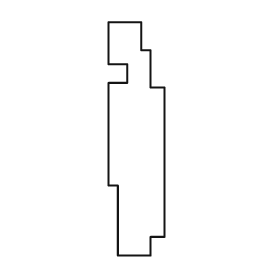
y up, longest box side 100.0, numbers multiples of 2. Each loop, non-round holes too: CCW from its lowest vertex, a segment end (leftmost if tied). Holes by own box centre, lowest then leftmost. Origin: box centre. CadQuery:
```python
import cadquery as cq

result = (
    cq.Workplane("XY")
    .moveTo(-8.0, -50.0)
    .lineTo(6.0, -50.0)
    .lineTo(6.0, -42.0)
    .lineTo(12.0, -42.0)
    .lineTo(12.0, 22.0)
    .lineTo(6.0, 22.0)
    .lineTo(6.0, 38.0)
    .lineTo(2.0, 38.0)
    .lineTo(2.0, 50.0)
    .lineTo(-12.0, 50.0)
    .lineTo(-12.0, 32.0)
    .lineTo(-4.0, 32.0)
    .lineTo(-4.0, 24.0)
    .lineTo(-12.0, 24.0)
    .lineTo(-12.0, -20.0)
    .lineTo(-8.0, -20.0)
    .close()
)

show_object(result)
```